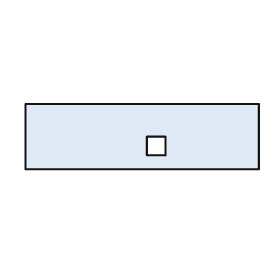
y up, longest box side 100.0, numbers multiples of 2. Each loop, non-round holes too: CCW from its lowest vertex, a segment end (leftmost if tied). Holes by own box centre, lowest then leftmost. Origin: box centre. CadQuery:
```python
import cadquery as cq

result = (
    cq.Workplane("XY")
    .moveTo(-50.0, -14.0)
    .lineTo(50.0, -14.0)
    .lineTo(50.0, 14.0)
    .lineTo(-50.0, 14.0)
    .close()
    .moveTo(2.0, -8.0)
    .lineTo(10.0, -8.0)
    .lineTo(10.0, 0.0)
    .lineTo(2.0, 0.0)
    .close()
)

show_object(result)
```